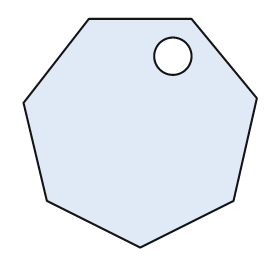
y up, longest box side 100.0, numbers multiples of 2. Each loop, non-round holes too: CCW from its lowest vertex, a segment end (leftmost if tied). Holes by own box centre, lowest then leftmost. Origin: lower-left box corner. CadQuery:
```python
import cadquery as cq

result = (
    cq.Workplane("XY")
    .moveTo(50.0, 0.0)
    .lineTo(90.0, 20.0)
    .lineTo(100.0, 64.0)
    .lineTo(72.0, 98.0)
    .lineTo(28.0, 98.0)
    .lineTo(0.0, 62.0)
    .lineTo(10.0, 20.0)
    .close()
    .moveTo(64.0, 82.0)
    .circle(8.0)
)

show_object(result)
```